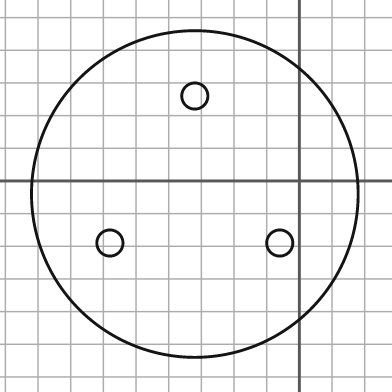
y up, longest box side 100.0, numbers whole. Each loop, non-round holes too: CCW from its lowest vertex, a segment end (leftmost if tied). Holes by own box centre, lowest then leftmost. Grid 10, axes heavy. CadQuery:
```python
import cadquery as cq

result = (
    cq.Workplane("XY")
    .moveTo(-32.0, -4.0)
    .circle(50.0)
    .moveTo(-58.0, -19.0)
    .circle(4.0)
    .moveTo(-6.0, -19.0)
    .circle(4.0)
    .moveTo(-32.0, 26.0)
    .circle(4.0)
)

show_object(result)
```